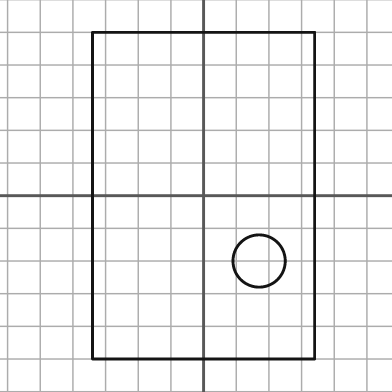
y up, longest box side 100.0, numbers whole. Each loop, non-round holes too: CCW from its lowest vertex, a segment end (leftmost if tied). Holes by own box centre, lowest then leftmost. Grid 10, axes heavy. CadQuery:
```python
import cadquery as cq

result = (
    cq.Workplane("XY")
    .moveTo(-34.0, -50.0)
    .lineTo(34.0, -50.0)
    .lineTo(34.0, 50.0)
    .lineTo(-34.0, 50.0)
    .close()
    .moveTo(17.0, -20.0)
    .circle(8.0)
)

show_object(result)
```